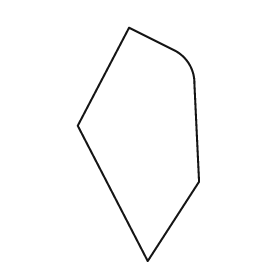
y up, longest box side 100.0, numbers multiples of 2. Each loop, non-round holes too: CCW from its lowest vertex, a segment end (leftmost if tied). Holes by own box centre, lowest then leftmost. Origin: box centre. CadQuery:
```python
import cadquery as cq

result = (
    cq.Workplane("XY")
    .moveTo(4.0, -50.0)
    .lineTo(26.0, -16.0)
    .lineTo(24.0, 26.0)
    .threePointArc((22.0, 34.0), (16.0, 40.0))
    .lineTo(-4.0, 50.0)
    .lineTo(-26.0, 8.0)
    .close()
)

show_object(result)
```